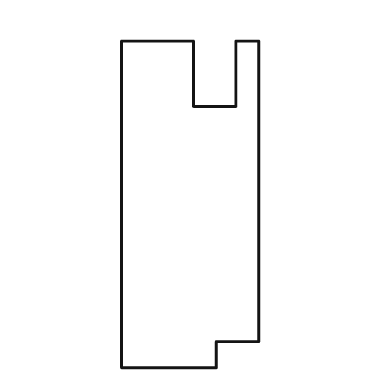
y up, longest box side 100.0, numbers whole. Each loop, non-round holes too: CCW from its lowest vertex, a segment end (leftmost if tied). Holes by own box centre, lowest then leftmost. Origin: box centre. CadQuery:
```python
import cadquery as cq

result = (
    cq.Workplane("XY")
    .moveTo(-21.0, -50.0)
    .lineTo(8.0, -50.0)
    .lineTo(8.0, -42.0)
    .lineTo(21.0, -42.0)
    .lineTo(21.0, 50.0)
    .lineTo(14.0, 50.0)
    .lineTo(14.0, 30.0)
    .lineTo(1.0, 30.0)
    .lineTo(1.0, 50.0)
    .lineTo(-21.0, 50.0)
    .close()
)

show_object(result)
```